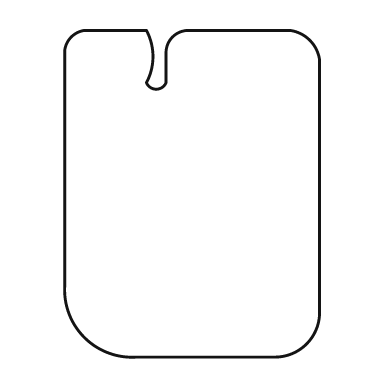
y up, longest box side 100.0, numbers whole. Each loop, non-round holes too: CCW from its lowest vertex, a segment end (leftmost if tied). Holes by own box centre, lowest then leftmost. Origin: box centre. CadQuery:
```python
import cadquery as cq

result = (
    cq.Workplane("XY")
    .moveTo(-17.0, -50.0)
    .lineTo(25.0, -50.0)
    .threePointArc((35.0, -46.0), (39.0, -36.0))
    .lineTo(39.0, 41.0)
    .threePointArc((36.0, 47.0), (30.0, 50.0))
    .lineTo(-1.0, 50.0)
    .threePointArc((-6.0, 48.0), (-8.0, 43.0))
    .lineTo(-8.0, 34.0)
    .threePointArc((-11.0, 32.0), (-14.0, 34.0))
    .threePointArc((-12.0, 42.0), (-14.0, 50.0))
    .lineTo(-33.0, 50.0)
    .threePointArc((-37.0, 48.0), (-39.0, 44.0))
    .lineTo(-39.0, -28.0)
    .threePointArc((-33.0, -44.0), (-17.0, -50.0))
    .close()
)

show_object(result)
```